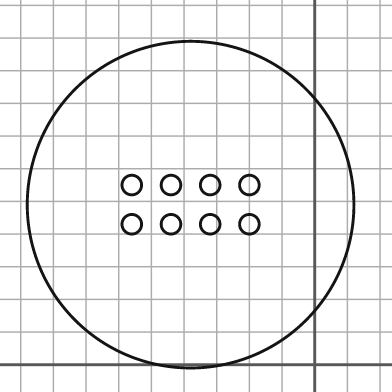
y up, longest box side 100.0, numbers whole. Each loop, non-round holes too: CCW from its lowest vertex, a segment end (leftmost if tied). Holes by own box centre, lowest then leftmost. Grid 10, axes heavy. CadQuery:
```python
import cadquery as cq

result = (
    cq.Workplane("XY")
    .moveTo(-38.0, 49.0)
    .circle(50.0)
    .moveTo(-56.0, 43.0)
    .circle(3.0)
    .moveTo(-44.0, 43.0)
    .circle(3.0)
    .moveTo(-32.0, 43.0)
    .circle(3.0)
    .moveTo(-20.0, 43.0)
    .circle(3.0)
    .moveTo(-56.0, 55.0)
    .circle(3.0)
    .moveTo(-44.0, 55.0)
    .circle(3.0)
    .moveTo(-32.0, 55.0)
    .circle(3.0)
    .moveTo(-20.0, 55.0)
    .circle(3.0)
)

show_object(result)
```